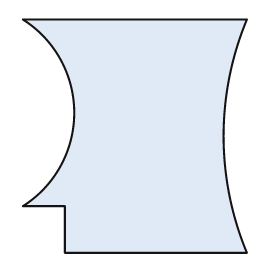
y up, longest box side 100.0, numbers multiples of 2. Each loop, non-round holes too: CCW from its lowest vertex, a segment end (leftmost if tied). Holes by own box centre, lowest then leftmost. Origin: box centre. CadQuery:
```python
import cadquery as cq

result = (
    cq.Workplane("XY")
    .moveTo(-30.0, -50.0)
    .lineTo(48.0, -50.0)
    .threePointArc((38.0, 0.0), (48.0, 50.0))
    .lineTo(-48.0, 50.0)
    .threePointArc((-26.0, 10.0), (-48.0, -30.0))
    .lineTo(-30.0, -30.0)
    .close()
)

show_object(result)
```